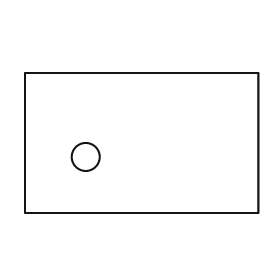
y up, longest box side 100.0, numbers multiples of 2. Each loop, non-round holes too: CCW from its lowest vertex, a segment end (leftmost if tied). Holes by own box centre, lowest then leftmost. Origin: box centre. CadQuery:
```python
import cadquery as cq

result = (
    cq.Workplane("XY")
    .moveTo(-50.0, -30.0)
    .lineTo(50.0, -30.0)
    .lineTo(50.0, 30.0)
    .lineTo(-50.0, 30.0)
    .close()
    .moveTo(-24.0, -6.0)
    .circle(6.0)
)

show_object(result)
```